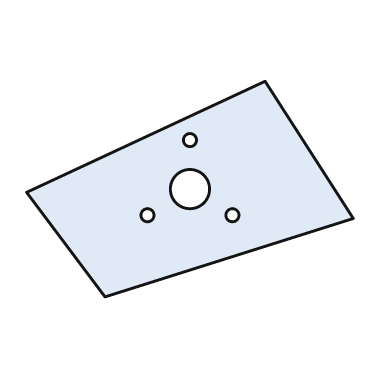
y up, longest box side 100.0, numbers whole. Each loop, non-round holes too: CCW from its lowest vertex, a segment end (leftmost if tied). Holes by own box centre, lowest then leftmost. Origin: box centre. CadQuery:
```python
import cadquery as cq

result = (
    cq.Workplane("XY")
    .moveTo(-26.0, -33.0)
    .lineTo(50.0, -9.0)
    .lineTo(23.0, 33.0)
    .lineTo(-50.0, -1.0)
    .close()
    .moveTo(-13.0, -8.0)
    .circle(2.0)
    .moveTo(13.0, -8.0)
    .circle(2.0)
    .moveTo(0.0, 0.0)
    .circle(6.0)
    .moveTo(0.0, 15.0)
    .circle(2.0)
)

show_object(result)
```